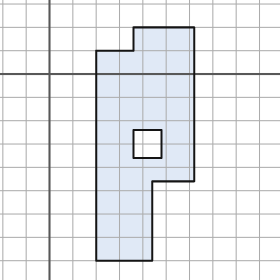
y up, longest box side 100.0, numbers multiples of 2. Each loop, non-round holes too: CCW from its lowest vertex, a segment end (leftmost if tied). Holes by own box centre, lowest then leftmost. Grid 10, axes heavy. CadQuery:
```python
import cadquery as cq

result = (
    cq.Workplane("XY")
    .moveTo(20.0, -80.0)
    .lineTo(44.0, -80.0)
    .lineTo(44.0, -46.0)
    .lineTo(62.0, -46.0)
    .lineTo(62.0, 20.0)
    .lineTo(36.0, 20.0)
    .lineTo(36.0, 10.0)
    .lineTo(20.0, 10.0)
    .close()
    .moveTo(36.0, -36.0)
    .lineTo(48.0, -36.0)
    .lineTo(48.0, -24.0)
    .lineTo(36.0, -24.0)
    .close()
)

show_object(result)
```